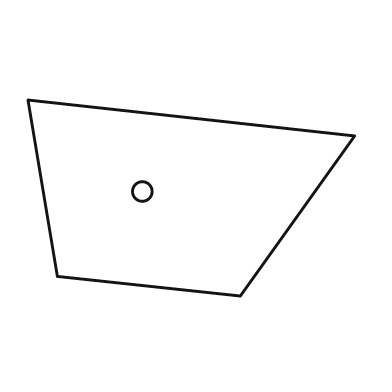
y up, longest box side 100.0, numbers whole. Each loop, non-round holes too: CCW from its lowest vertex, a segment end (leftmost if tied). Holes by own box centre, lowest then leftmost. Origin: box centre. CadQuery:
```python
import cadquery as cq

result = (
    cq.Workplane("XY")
    .moveTo(15.0, -30.0)
    .lineTo(50.0, 19.0)
    .lineTo(-50.0, 30.0)
    .lineTo(-41.0, -24.0)
    .close()
    .moveTo(-15.0, 2.0)
    .circle(3.0)
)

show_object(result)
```